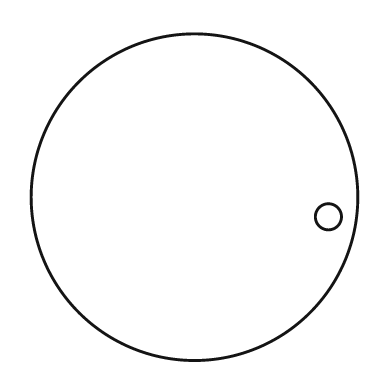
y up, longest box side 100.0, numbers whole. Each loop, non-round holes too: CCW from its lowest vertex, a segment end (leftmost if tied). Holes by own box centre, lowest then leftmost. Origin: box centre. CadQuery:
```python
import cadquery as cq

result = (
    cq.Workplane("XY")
    .moveTo(0.0, 0.0)
    .circle(50.0)
    .moveTo(41.0, -6.0)
    .circle(4.0)
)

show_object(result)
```